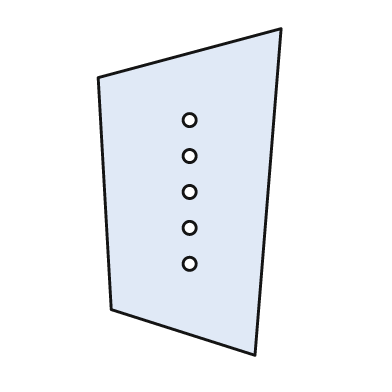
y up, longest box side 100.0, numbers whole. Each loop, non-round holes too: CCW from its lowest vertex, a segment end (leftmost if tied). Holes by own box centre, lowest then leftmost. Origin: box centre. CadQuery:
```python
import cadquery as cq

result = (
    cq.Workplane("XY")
    .moveTo(20.0, -50.0)
    .lineTo(28.0, 50.0)
    .lineTo(-28.0, 35.0)
    .lineTo(-24.0, -36.0)
    .close()
    .moveTo(0.0, -22.0)
    .circle(2.0)
    .moveTo(0.0, -11.0)
    .circle(2.0)
    .moveTo(0.0, 0.0)
    .circle(2.0)
    .moveTo(0.0, 11.0)
    .circle(2.0)
    .moveTo(0.0, 22.0)
    .circle(2.0)
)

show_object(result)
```